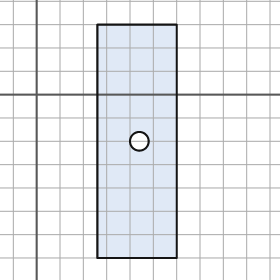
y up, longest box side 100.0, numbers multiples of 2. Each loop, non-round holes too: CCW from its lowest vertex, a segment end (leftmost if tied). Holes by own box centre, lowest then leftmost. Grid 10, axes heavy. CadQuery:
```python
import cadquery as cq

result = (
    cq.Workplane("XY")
    .moveTo(26.0, -70.0)
    .lineTo(60.0, -70.0)
    .lineTo(60.0, 30.0)
    .lineTo(26.0, 30.0)
    .close()
    .moveTo(44.0, -20.0)
    .circle(4.0)
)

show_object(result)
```